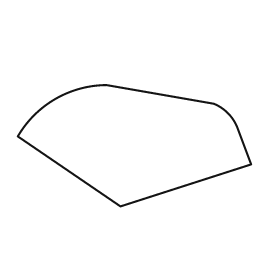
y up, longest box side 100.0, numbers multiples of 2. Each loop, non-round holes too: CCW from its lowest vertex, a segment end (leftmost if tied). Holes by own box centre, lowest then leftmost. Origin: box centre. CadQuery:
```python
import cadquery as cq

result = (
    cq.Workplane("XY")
    .moveTo(-6.0, -26.0)
    .lineTo(50.0, -8.0)
    .lineTo(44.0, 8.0)
    .threePointArc((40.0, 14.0), (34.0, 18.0))
    .lineTo(-12.0, 26.0)
    .threePointArc((-34.0, 20.0), (-50.0, 4.0))
    .close()
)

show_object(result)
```